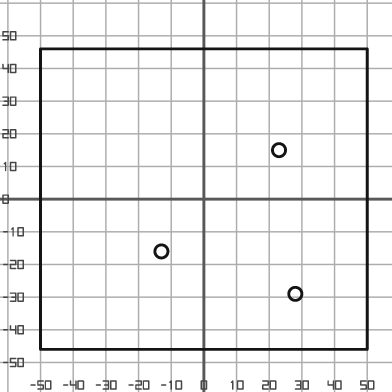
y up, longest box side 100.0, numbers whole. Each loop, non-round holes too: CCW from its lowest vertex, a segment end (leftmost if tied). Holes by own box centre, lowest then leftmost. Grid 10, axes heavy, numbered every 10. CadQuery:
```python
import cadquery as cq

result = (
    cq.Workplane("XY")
    .moveTo(-50.0, -46.0)
    .lineTo(50.0, -46.0)
    .lineTo(50.0, 46.0)
    .lineTo(-50.0, 46.0)
    .close()
    .moveTo(28.0, -29.0)
    .circle(2.0)
    .moveTo(-13.0, -16.0)
    .circle(2.0)
    .moveTo(23.0, 15.0)
    .circle(2.0)
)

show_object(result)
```